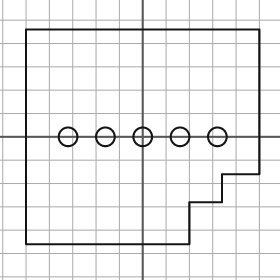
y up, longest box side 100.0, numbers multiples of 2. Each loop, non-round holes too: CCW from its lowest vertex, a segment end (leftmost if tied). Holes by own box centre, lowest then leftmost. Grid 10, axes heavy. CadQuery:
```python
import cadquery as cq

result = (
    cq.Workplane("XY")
    .moveTo(-50.0, -46.0)
    .lineTo(20.0, -46.0)
    .lineTo(20.0, -28.0)
    .lineTo(34.0, -28.0)
    .lineTo(34.0, -16.0)
    .lineTo(50.0, -16.0)
    .lineTo(50.0, 46.0)
    .lineTo(-50.0, 46.0)
    .close()
    .moveTo(-32.0, 0.0)
    .circle(4.0)
    .moveTo(-16.0, 0.0)
    .circle(4.0)
    .moveTo(0.0, 0.0)
    .circle(4.0)
    .moveTo(16.0, 0.0)
    .circle(4.0)
    .moveTo(32.0, 0.0)
    .circle(4.0)
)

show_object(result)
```